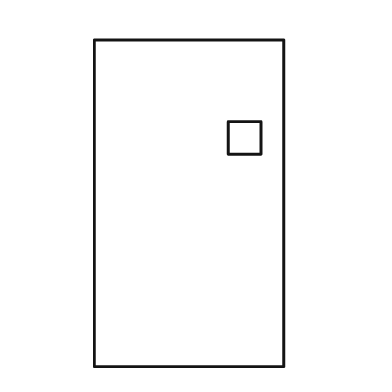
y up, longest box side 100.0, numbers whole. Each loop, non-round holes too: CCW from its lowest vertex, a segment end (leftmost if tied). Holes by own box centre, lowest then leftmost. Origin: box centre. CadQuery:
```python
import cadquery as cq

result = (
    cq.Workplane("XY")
    .moveTo(-29.0, -50.0)
    .lineTo(29.0, -50.0)
    .lineTo(29.0, 50.0)
    .lineTo(-29.0, 50.0)
    .close()
    .moveTo(12.0, 15.0)
    .lineTo(22.0, 15.0)
    .lineTo(22.0, 25.0)
    .lineTo(12.0, 25.0)
    .close()
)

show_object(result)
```